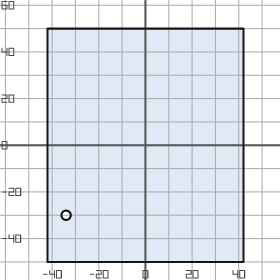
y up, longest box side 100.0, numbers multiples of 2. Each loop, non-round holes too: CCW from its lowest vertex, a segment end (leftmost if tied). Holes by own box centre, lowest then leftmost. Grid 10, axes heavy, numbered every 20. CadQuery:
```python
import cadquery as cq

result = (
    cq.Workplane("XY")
    .moveTo(-42.0, -50.0)
    .lineTo(42.0, -50.0)
    .lineTo(42.0, 50.0)
    .lineTo(-42.0, 50.0)
    .close()
    .moveTo(-34.0, -30.0)
    .circle(2.0)
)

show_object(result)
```